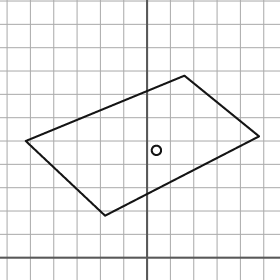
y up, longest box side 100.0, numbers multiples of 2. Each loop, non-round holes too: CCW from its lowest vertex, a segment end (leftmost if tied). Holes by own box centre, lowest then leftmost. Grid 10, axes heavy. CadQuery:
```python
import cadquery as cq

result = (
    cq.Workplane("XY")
    .moveTo(-18.0, 18.0)
    .lineTo(48.0, 52.0)
    .lineTo(16.0, 78.0)
    .lineTo(-52.0, 50.0)
    .close()
    .moveTo(4.0, 46.0)
    .circle(2.0)
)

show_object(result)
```